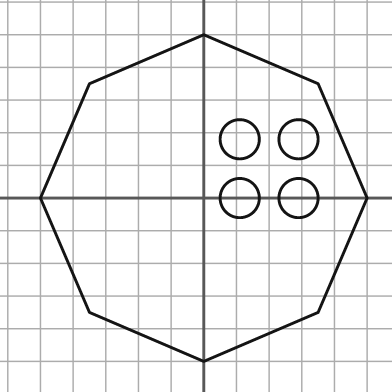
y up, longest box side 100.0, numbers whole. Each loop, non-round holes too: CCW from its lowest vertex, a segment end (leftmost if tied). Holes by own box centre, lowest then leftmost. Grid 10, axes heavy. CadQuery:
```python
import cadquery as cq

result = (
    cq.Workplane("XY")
    .moveTo(0.0, -50.0)
    .lineTo(35.0, -35.0)
    .lineTo(50.0, 0.0)
    .lineTo(35.0, 35.0)
    .lineTo(0.0, 50.0)
    .lineTo(-35.0, 35.0)
    .lineTo(-50.0, 0.0)
    .lineTo(-35.0, -35.0)
    .close()
    .moveTo(11.0, 0.0)
    .circle(6.0)
    .moveTo(29.0, 0.0)
    .circle(6.0)
    .moveTo(11.0, 18.0)
    .circle(6.0)
    .moveTo(29.0, 18.0)
    .circle(6.0)
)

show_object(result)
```